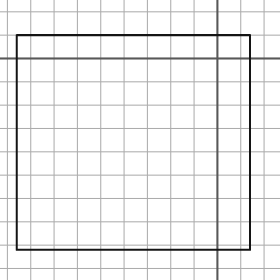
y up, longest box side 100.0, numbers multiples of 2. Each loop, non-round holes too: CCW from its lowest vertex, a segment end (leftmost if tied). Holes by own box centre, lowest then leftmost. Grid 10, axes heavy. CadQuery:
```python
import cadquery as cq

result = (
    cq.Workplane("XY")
    .moveTo(-86.0, -82.0)
    .lineTo(14.0, -82.0)
    .lineTo(14.0, 10.0)
    .lineTo(-86.0, 10.0)
    .close()
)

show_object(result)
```